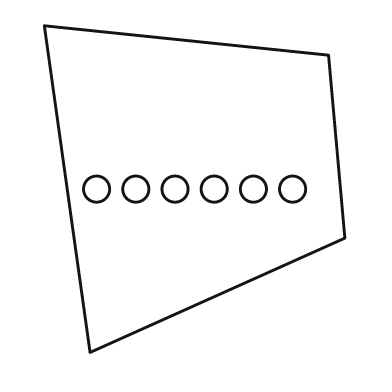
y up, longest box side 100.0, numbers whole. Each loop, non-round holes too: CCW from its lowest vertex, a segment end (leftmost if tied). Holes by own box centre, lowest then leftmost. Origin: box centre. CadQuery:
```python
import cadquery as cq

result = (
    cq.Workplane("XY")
    .moveTo(-32.0, -50.0)
    .lineTo(46.0, -15.0)
    .lineTo(41.0, 41.0)
    .lineTo(-46.0, 50.0)
    .close()
    .moveTo(-30.0, 0.0)
    .circle(4.0)
    .moveTo(-18.0, 0.0)
    .circle(4.0)
    .moveTo(-6.0, 0.0)
    .circle(4.0)
    .moveTo(6.0, 0.0)
    .circle(4.0)
    .moveTo(18.0, 0.0)
    .circle(4.0)
    .moveTo(30.0, 0.0)
    .circle(4.0)
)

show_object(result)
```